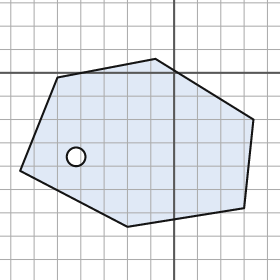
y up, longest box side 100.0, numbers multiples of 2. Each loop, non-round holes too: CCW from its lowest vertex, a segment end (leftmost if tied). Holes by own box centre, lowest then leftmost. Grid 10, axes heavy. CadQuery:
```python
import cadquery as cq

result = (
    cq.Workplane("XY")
    .moveTo(-20.0, -66.0)
    .lineTo(30.0, -58.0)
    .lineTo(34.0, -20.0)
    .lineTo(-8.0, 6.0)
    .lineTo(-50.0, -2.0)
    .lineTo(-66.0, -42.0)
    .close()
    .moveTo(-42.0, -36.0)
    .circle(4.0)
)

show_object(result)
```